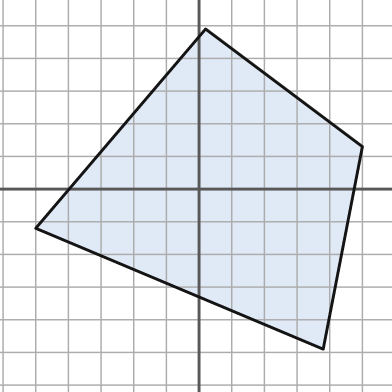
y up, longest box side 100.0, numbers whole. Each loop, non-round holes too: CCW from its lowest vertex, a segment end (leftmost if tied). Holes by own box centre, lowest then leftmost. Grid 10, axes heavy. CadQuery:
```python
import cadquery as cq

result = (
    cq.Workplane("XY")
    .moveTo(38.0, -49.0)
    .lineTo(50.0, 13.0)
    .lineTo(2.0, 49.0)
    .lineTo(-50.0, -12.0)
    .close()
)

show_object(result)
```